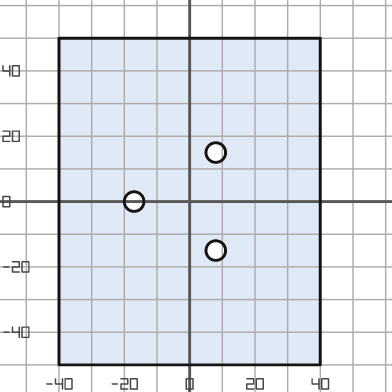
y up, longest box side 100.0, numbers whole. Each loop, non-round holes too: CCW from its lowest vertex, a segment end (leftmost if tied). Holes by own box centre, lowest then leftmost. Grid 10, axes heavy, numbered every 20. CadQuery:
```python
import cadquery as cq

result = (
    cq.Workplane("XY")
    .moveTo(-40.0, -50.0)
    .lineTo(40.0, -50.0)
    .lineTo(40.0, 50.0)
    .lineTo(-40.0, 50.0)
    .close()
    .moveTo(8.0, -15.0)
    .circle(3.0)
    .moveTo(-17.0, 0.0)
    .circle(3.0)
    .moveTo(8.0, 15.0)
    .circle(3.0)
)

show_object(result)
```